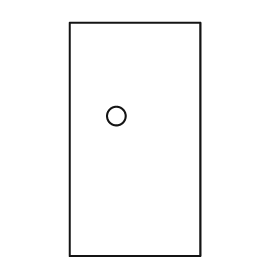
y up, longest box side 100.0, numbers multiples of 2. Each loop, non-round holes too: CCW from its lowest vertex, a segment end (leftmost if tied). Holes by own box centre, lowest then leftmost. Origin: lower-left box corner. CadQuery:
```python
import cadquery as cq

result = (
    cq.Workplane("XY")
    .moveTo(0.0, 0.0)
    .lineTo(56.0, 0.0)
    .lineTo(56.0, 100.0)
    .lineTo(0.0, 100.0)
    .close()
    .moveTo(20.0, 60.0)
    .circle(4.0)
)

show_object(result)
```